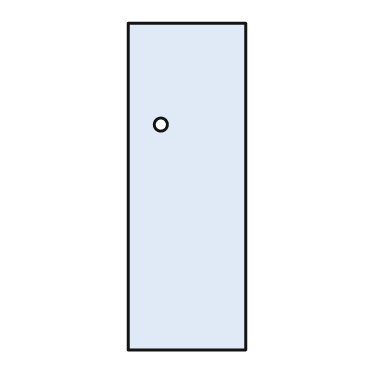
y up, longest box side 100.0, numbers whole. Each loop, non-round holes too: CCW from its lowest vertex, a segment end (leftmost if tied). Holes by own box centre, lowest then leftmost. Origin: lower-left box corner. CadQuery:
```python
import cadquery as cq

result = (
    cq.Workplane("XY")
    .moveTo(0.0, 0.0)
    .lineTo(36.0, 0.0)
    .lineTo(36.0, 100.0)
    .lineTo(0.0, 100.0)
    .close()
    .moveTo(10.0, 69.0)
    .circle(2.0)
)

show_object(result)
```